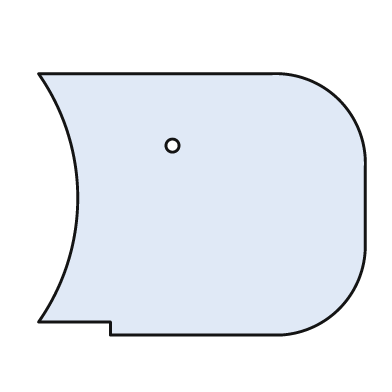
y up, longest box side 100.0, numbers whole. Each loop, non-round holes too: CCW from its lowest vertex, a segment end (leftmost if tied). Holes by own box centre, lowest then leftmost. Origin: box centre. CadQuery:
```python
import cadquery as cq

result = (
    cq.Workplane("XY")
    .moveTo(-28.0, -40.0)
    .lineTo(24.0, -40.0)
    .threePointArc((42.0, -32.0), (50.0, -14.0))
    .lineTo(50.0, 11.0)
    .threePointArc((42.0, 32.0), (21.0, 40.0))
    .lineTo(-50.0, 40.0)
    .threePointArc((-38.0, 2.0), (-50.0, -36.0))
    .lineTo(-28.0, -36.0)
    .close()
    .moveTo(-9.0, 18.0)
    .circle(2.0)
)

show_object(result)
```